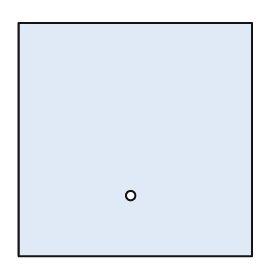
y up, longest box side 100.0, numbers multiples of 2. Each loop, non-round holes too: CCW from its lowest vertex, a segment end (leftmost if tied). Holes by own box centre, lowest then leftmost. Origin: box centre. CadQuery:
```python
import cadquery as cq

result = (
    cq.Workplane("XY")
    .moveTo(-50.0, -50.0)
    .lineTo(50.0, -50.0)
    .lineTo(50.0, 50.0)
    .lineTo(-50.0, 50.0)
    .close()
    .moveTo(-2.0, -24.0)
    .circle(2.0)
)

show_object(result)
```